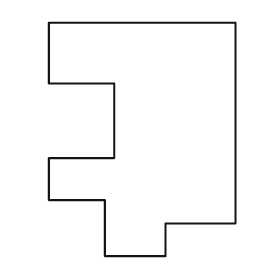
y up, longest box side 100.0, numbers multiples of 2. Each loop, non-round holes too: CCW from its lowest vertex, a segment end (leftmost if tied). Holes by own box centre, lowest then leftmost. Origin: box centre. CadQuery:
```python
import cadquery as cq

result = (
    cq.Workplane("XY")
    .moveTo(-16.0, -50.0)
    .lineTo(10.0, -50.0)
    .lineTo(10.0, -36.0)
    .lineTo(40.0, -36.0)
    .lineTo(40.0, 50.0)
    .lineTo(-40.0, 50.0)
    .lineTo(-40.0, 24.0)
    .lineTo(-12.0, 24.0)
    .lineTo(-12.0, -8.0)
    .lineTo(-40.0, -8.0)
    .lineTo(-40.0, -26.0)
    .lineTo(-16.0, -26.0)
    .close()
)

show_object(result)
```